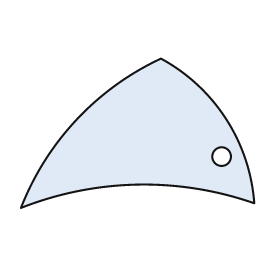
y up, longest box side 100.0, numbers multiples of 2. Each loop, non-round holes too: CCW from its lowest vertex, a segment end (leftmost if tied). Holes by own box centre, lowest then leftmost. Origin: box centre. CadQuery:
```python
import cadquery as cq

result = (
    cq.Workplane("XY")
    .moveTo(-50.0, -32.0)
    .threePointArc((0.0, -22.0), (50.0, -30.0))
    .threePointArc((38.0, 6.0), (10.0, 32.0))
    .threePointArc((-26.0, 6.0), (-50.0, -32.0))
    .close()
    .moveTo(36.0, -10.0)
    .circle(4.0)
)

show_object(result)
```